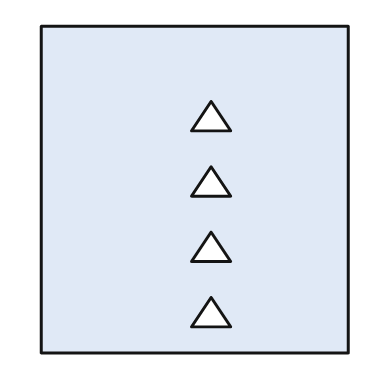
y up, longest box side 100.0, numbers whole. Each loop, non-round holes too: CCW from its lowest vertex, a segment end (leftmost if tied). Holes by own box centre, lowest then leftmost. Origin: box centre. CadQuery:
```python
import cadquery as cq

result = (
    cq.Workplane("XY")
    .moveTo(-47.0, -50.0)
    .lineTo(47.0, -50.0)
    .lineTo(47.0, 50.0)
    .lineTo(-47.0, 50.0)
    .close()
    .moveTo(-1.0, -42.0)
    .lineTo(11.0, -42.0)
    .lineTo(5.0, -33.0)
    .close()
    .moveTo(-1.0, -22.0)
    .lineTo(11.0, -22.0)
    .lineTo(5.0, -13.0)
    .close()
    .moveTo(-1.0, -2.0)
    .lineTo(11.0, -2.0)
    .lineTo(5.0, 7.0)
    .close()
    .moveTo(-1.0, 18.0)
    .lineTo(11.0, 18.0)
    .lineTo(5.0, 27.0)
    .close()
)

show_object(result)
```